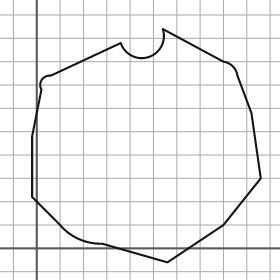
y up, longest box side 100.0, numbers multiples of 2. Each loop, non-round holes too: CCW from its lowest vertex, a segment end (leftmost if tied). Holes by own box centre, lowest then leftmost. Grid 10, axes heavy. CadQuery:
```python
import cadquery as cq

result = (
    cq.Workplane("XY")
    .moveTo(56.0, -6.0)
    .lineTo(80.0, 10.0)
    .lineTo(96.0, 30.0)
    .lineTo(92.0, 58.0)
    .lineTo(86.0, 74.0)
    .threePointArc((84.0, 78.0), (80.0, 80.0))
    .lineTo(54.0, 94.0)
    .threePointArc((48.0, 82.0), (36.0, 88.0))
    .lineTo(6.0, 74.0)
    .threePointArc((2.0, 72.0), (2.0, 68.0))
    .lineTo(-2.0, 48.0)
    .lineTo(-2.0, 22.0)
    .lineTo(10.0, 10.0)
    .threePointArc((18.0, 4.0), (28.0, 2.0))
    .close()
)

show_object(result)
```